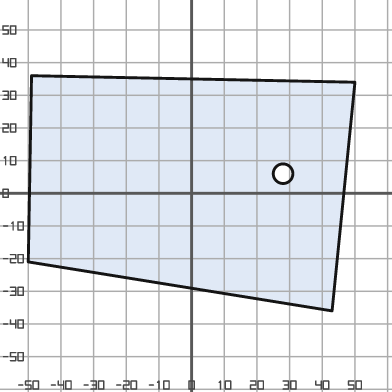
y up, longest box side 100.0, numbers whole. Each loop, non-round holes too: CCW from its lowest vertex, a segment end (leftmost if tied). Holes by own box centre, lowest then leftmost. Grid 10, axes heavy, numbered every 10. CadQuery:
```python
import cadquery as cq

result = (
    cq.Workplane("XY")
    .moveTo(43.0, -36.0)
    .lineTo(50.0, 34.0)
    .lineTo(-49.0, 36.0)
    .lineTo(-50.0, -21.0)
    .close()
    .moveTo(28.0, 6.0)
    .circle(3.0)
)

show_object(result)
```